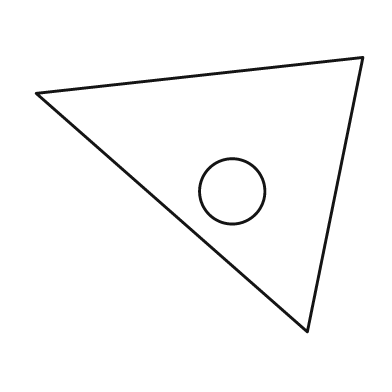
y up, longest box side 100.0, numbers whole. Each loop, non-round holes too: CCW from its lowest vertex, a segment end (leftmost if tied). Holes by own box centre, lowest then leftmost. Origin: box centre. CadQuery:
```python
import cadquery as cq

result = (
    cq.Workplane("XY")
    .moveTo(33.0, -42.0)
    .lineTo(50.0, 42.0)
    .lineTo(-50.0, 31.0)
    .close()
    .moveTo(10.0, 1.0)
    .circle(10.0)
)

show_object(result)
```